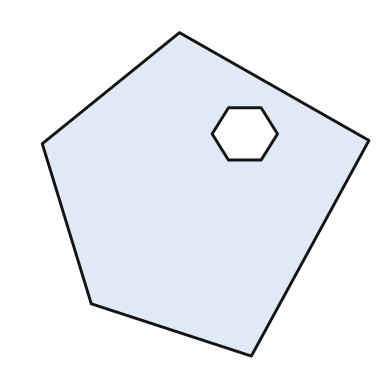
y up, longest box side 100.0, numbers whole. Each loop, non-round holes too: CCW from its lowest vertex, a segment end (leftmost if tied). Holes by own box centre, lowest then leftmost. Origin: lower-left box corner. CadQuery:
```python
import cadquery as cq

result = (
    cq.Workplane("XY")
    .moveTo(64.0, 0.0)
    .lineTo(100.0, 66.0)
    .lineTo(42.0, 99.0)
    .lineTo(0.0, 65.0)
    .lineTo(15.0, 16.0)
    .close()
    .moveTo(57.0, 60.0)
    .lineTo(67.0, 60.0)
    .lineTo(72.0, 68.0)
    .lineTo(67.0, 76.0)
    .lineTo(57.0, 76.0)
    .lineTo(52.0, 68.0)
    .close()
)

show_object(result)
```